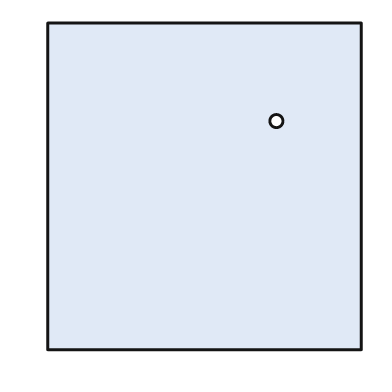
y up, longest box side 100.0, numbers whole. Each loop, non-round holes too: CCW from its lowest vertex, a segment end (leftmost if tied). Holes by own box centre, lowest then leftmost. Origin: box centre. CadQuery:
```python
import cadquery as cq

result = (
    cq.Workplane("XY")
    .moveTo(-48.0, -50.0)
    .lineTo(48.0, -50.0)
    .lineTo(48.0, 50.0)
    .lineTo(-48.0, 50.0)
    .close()
    .moveTo(22.0, 20.0)
    .circle(2.0)
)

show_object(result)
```